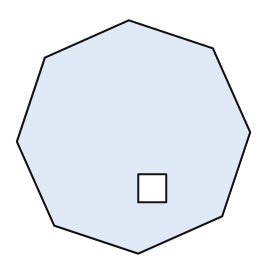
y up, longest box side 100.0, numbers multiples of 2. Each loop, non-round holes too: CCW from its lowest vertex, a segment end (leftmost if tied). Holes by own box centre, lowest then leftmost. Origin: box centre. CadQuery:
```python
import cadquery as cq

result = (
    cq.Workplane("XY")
    .moveTo(2.0, -50.0)
    .lineTo(38.0, -34.0)
    .lineTo(50.0, 2.0)
    .lineTo(34.0, 38.0)
    .lineTo(-2.0, 50.0)
    .lineTo(-38.0, 34.0)
    .lineTo(-50.0, -2.0)
    .lineTo(-34.0, -38.0)
    .close()
    .moveTo(2.0, -28.0)
    .lineTo(14.0, -28.0)
    .lineTo(14.0, -16.0)
    .lineTo(2.0, -16.0)
    .close()
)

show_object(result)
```